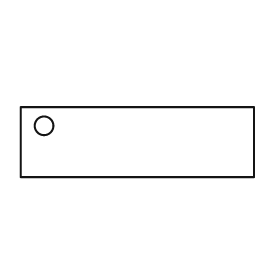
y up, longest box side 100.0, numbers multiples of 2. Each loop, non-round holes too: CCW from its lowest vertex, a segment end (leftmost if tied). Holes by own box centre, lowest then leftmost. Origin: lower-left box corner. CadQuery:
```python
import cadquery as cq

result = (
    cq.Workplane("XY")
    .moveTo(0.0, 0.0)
    .lineTo(100.0, 0.0)
    .lineTo(100.0, 30.0)
    .lineTo(0.0, 30.0)
    .close()
    .moveTo(10.0, 22.0)
    .circle(4.0)
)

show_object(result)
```